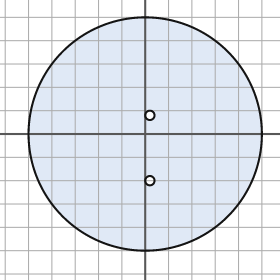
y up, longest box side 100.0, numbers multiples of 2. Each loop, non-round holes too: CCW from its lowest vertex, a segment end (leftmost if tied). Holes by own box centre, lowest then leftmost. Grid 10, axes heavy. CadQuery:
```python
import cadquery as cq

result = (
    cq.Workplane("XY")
    .moveTo(0.0, 0.0)
    .circle(50.0)
    .moveTo(2.0, -20.0)
    .circle(2.0)
    .moveTo(2.0, 8.0)
    .circle(2.0)
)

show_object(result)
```